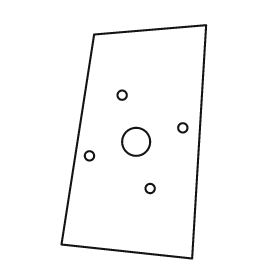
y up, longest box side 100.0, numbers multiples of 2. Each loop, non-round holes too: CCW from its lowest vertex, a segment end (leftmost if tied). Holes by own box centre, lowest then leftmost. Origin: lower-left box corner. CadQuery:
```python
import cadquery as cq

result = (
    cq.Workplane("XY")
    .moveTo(56.0, 0.0)
    .lineTo(62.0, 100.0)
    .lineTo(14.0, 96.0)
    .lineTo(0.0, 6.0)
    .close()
    .moveTo(38.0, 30.0)
    .circle(2.0)
    .moveTo(12.0, 44.0)
    .circle(2.0)
    .moveTo(32.0, 50.0)
    .circle(6.0)
    .moveTo(52.0, 56.0)
    .circle(2.0)
    .moveTo(26.0, 70.0)
    .circle(2.0)
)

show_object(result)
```